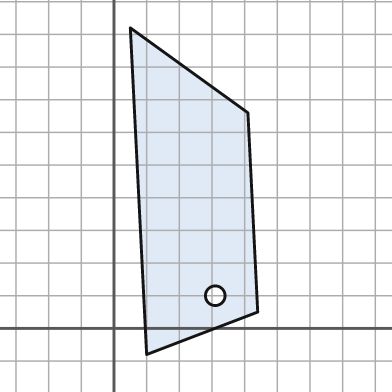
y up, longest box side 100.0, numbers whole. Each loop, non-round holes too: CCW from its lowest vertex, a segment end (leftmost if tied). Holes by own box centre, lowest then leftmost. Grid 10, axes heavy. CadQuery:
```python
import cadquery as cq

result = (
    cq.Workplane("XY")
    .moveTo(10.0, -8.0)
    .lineTo(44.0, 5.0)
    .lineTo(41.0, 66.0)
    .lineTo(5.0, 92.0)
    .close()
    .moveTo(31.0, 10.0)
    .circle(3.0)
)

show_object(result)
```